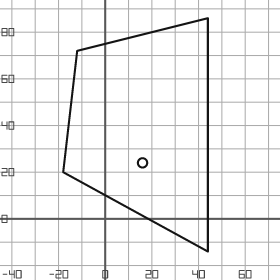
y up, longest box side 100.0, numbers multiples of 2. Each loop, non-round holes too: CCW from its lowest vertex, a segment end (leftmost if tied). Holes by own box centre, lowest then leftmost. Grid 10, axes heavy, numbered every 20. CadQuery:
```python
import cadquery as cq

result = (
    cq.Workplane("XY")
    .moveTo(44.0, -14.0)
    .lineTo(44.0, 86.0)
    .lineTo(-12.0, 72.0)
    .lineTo(-18.0, 20.0)
    .close()
    .moveTo(16.0, 24.0)
    .circle(2.0)
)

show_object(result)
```